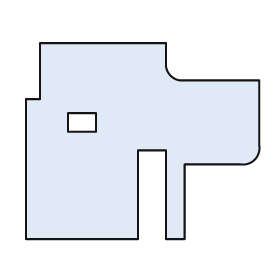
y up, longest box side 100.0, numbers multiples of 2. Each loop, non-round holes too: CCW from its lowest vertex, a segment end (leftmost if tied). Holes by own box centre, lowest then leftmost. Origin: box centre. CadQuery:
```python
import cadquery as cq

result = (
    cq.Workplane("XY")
    .moveTo(-50.0, -42.0)
    .lineTo(-2.0, -42.0)
    .lineTo(-2.0, -4.0)
    .lineTo(10.0, -4.0)
    .lineTo(10.0, -42.0)
    .lineTo(18.0, -42.0)
    .lineTo(18.0, -10.0)
    .lineTo(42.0, -10.0)
    .threePointArc((48.0, -8.0), (50.0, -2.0))
    .lineTo(50.0, 26.0)
    .lineTo(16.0, 26.0)
    .threePointArc((12.0, 28.0), (10.0, 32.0))
    .lineTo(10.0, 42.0)
    .lineTo(-44.0, 42.0)
    .lineTo(-44.0, 18.0)
    .lineTo(-50.0, 18.0)
    .close()
    .moveTo(-32.0, 4.0)
    .lineTo(-20.0, 4.0)
    .lineTo(-20.0, 12.0)
    .lineTo(-32.0, 12.0)
    .close()
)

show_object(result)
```